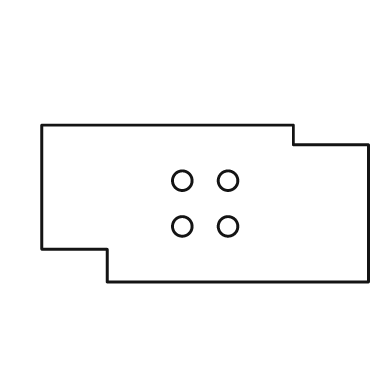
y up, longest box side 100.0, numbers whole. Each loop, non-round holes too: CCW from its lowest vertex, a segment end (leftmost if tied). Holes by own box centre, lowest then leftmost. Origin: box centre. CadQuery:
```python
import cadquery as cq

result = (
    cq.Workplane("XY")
    .moveTo(-30.0, -24.0)
    .lineTo(50.0, -24.0)
    .lineTo(50.0, 18.0)
    .lineTo(27.0, 18.0)
    .lineTo(27.0, 24.0)
    .lineTo(-50.0, 24.0)
    .lineTo(-50.0, -14.0)
    .lineTo(-30.0, -14.0)
    .close()
    .moveTo(-7.0, -7.0)
    .circle(3.0)
    .moveTo(7.0, -7.0)
    .circle(3.0)
    .moveTo(-7.0, 7.0)
    .circle(3.0)
    .moveTo(7.0, 7.0)
    .circle(3.0)
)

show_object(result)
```